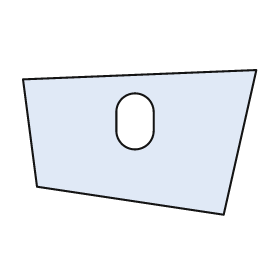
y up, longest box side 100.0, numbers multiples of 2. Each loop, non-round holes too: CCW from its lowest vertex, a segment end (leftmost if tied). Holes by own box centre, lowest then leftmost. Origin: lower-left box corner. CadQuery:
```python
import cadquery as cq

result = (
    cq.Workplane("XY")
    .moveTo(86.0, 0.0)
    .lineTo(100.0, 62.0)
    .lineTo(0.0, 58.0)
    .lineTo(6.0, 12.0)
    .close()
    .moveTo(40.0, 36.0)
    .threePointArc((48.0, 28.0), (56.0, 36.0))
    .lineTo(56.0, 44.0)
    .threePointArc((48.0, 52.0), (40.0, 44.0))
    .close()
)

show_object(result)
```